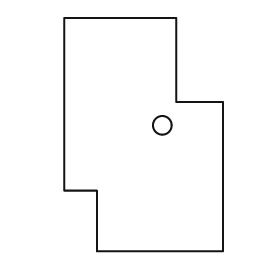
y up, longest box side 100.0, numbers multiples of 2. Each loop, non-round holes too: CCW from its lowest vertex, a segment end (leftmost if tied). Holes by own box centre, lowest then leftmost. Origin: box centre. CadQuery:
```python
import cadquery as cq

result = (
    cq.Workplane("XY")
    .moveTo(-20.0, -50.0)
    .lineTo(34.0, -50.0)
    .lineTo(34.0, 14.0)
    .lineTo(14.0, 14.0)
    .lineTo(14.0, 50.0)
    .lineTo(-34.0, 50.0)
    .lineTo(-34.0, -24.0)
    .lineTo(-20.0, -24.0)
    .close()
    .moveTo(8.0, 4.0)
    .circle(4.0)
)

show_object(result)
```